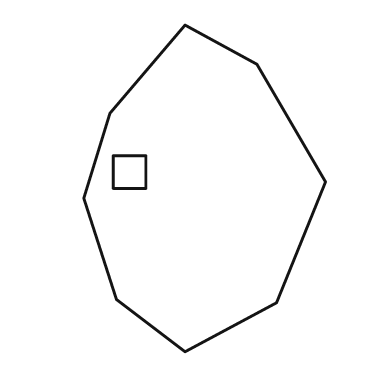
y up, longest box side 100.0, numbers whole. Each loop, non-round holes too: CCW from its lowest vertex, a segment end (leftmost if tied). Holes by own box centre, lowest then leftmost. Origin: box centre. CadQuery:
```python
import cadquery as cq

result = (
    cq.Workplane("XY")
    .moveTo(-6.0, -50.0)
    .lineTo(22.0, -35.0)
    .lineTo(37.0, 2.0)
    .lineTo(16.0, 38.0)
    .lineTo(-6.0, 50.0)
    .lineTo(-29.0, 23.0)
    .lineTo(-37.0, -3.0)
    .lineTo(-27.0, -34.0)
    .close()
    .moveTo(-28.0, 0.0)
    .lineTo(-18.0, 0.0)
    .lineTo(-18.0, 10.0)
    .lineTo(-28.0, 10.0)
    .close()
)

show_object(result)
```